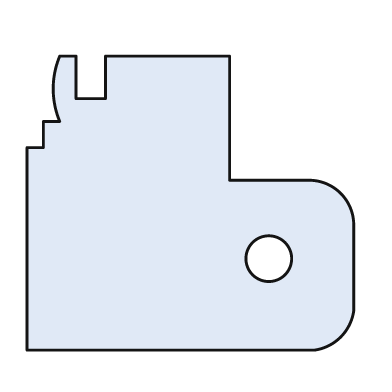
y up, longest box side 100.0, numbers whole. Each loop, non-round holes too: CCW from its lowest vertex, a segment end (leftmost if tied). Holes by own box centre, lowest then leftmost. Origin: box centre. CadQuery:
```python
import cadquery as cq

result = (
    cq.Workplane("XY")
    .moveTo(-50.0, -45.0)
    .lineTo(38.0, -45.0)
    .threePointArc((46.0, -41.0), (50.0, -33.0))
    .lineTo(50.0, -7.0)
    .threePointArc((46.0, 3.0), (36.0, 7.0))
    .lineTo(12.0, 7.0)
    .lineTo(12.0, 45.0)
    .lineTo(-26.0, 45.0)
    .lineTo(-26.0, 32.0)
    .lineTo(-35.0, 32.0)
    .lineTo(-35.0, 45.0)
    .lineTo(-40.0, 45.0)
    .threePointArc((-42.0, 35.0), (-40.0, 25.0))
    .lineTo(-45.0, 25.0)
    .lineTo(-45.0, 17.0)
    .lineTo(-50.0, 17.0)
    .close()
    .moveTo(24.0, -17.0)
    .circle(7.0)
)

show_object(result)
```